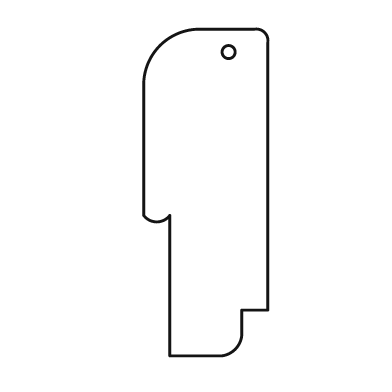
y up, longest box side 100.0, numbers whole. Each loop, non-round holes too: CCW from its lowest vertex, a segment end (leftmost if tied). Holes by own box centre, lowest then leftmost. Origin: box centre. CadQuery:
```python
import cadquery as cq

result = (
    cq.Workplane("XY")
    .moveTo(-11.0, -50.0)
    .lineTo(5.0, -50.0)
    .threePointArc((9.0, -48.0), (11.0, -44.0))
    .lineTo(11.0, -36.0)
    .lineTo(19.0, -36.0)
    .lineTo(19.0, 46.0)
    .threePointArc((18.0, 49.0), (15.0, 50.0))
    .lineTo(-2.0, 50.0)
    .threePointArc((-14.0, 45.0), (-19.0, 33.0))
    .lineTo(-19.0, -7.0)
    .threePointArc((-15.0, -9.0), (-11.0, -7.0))
    .close()
    .moveTo(7.0, 43.0)
    .circle(2.0)
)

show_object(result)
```